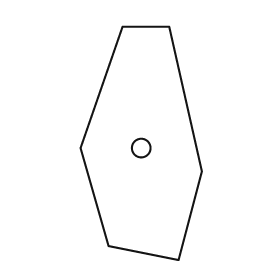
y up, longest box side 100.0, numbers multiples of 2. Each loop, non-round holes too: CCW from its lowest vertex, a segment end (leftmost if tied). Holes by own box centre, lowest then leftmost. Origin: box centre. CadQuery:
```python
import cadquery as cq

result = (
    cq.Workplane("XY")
    .moveTo(16.0, -50.0)
    .lineTo(26.0, -12.0)
    .lineTo(12.0, 50.0)
    .lineTo(-8.0, 50.0)
    .lineTo(-26.0, -2.0)
    .lineTo(-14.0, -44.0)
    .close()
    .moveTo(0.0, -2.0)
    .circle(4.0)
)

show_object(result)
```